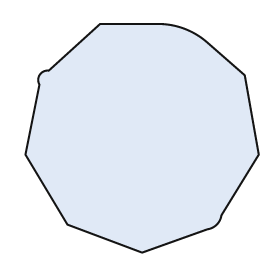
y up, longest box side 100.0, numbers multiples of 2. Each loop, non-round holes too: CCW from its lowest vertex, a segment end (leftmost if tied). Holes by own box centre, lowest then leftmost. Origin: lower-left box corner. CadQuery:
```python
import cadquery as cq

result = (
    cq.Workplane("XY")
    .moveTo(50.0, 0.0)
    .lineTo(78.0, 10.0)
    .threePointArc((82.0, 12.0), (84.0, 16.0))
    .lineTo(100.0, 42.0)
    .lineTo(94.0, 76.0)
    .lineTo(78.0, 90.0)
    .threePointArc((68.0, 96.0), (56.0, 98.0))
    .lineTo(32.0, 98.0)
    .lineTo(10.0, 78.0)
    .threePointArc((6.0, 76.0), (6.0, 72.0))
    .lineTo(0.0, 42.0)
    .lineTo(18.0, 12.0)
    .close()
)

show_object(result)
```